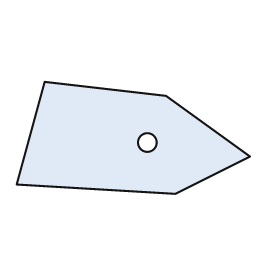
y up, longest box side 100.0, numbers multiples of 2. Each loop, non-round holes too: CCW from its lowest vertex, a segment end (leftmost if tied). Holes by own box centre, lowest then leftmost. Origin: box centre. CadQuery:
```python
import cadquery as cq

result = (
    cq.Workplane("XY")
    .moveTo(18.0, -24.0)
    .lineTo(50.0, -8.0)
    .lineTo(14.0, 18.0)
    .lineTo(-38.0, 24.0)
    .lineTo(-50.0, -20.0)
    .close()
    .moveTo(6.0, -2.0)
    .circle(4.0)
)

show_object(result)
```